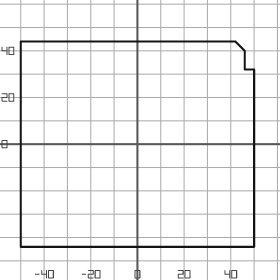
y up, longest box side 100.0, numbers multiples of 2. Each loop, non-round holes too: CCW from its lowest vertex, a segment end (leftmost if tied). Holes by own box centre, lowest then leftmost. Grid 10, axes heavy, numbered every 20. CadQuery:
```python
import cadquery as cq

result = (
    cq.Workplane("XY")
    .moveTo(-50.0, -44.0)
    .lineTo(50.0, -44.0)
    .lineTo(50.0, 32.0)
    .lineTo(46.0, 32.0)
    .lineTo(46.0, 40.0)
    .lineTo(42.0, 44.0)
    .lineTo(-50.0, 44.0)
    .close()
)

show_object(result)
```